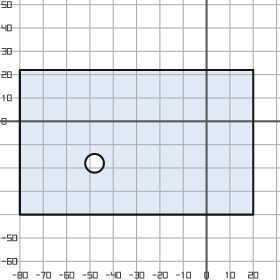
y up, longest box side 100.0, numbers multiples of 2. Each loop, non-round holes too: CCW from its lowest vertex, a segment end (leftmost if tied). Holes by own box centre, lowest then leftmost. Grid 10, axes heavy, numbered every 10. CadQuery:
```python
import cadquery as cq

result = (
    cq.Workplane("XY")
    .moveTo(-80.0, -40.0)
    .lineTo(20.0, -40.0)
    .lineTo(20.0, 22.0)
    .lineTo(-80.0, 22.0)
    .close()
    .moveTo(-48.0, -18.0)
    .circle(4.0)
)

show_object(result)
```